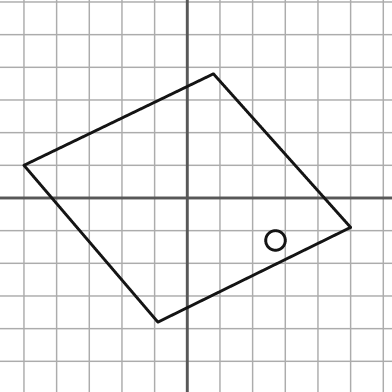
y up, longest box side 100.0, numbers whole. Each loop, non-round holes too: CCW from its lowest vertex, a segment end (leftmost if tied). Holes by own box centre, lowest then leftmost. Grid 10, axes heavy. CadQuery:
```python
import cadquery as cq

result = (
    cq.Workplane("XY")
    .moveTo(-9.0, -38.0)
    .lineTo(50.0, -9.0)
    .lineTo(8.0, 38.0)
    .lineTo(-50.0, 10.0)
    .close()
    .moveTo(27.0, -13.0)
    .circle(3.0)
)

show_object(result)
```